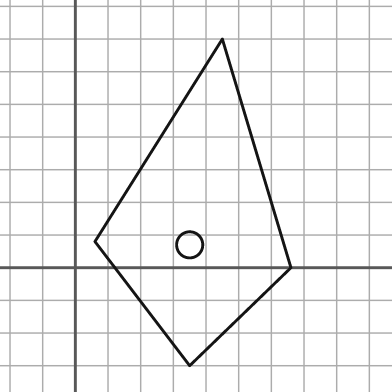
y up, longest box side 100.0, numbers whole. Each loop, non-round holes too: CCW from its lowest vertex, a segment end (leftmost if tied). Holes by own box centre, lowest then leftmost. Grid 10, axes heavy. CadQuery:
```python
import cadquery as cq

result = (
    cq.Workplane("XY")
    .moveTo(35.0, -30.0)
    .lineTo(66.0, 0.0)
    .lineTo(45.0, 70.0)
    .lineTo(6.0, 8.0)
    .close()
    .moveTo(35.0, 7.0)
    .circle(4.0)
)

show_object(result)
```